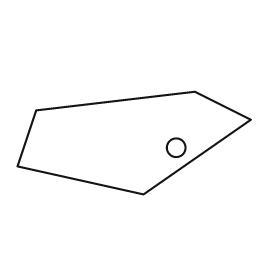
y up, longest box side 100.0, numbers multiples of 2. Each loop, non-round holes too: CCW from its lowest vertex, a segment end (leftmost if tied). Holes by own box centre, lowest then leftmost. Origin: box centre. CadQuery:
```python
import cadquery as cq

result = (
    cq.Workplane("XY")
    .moveTo(4.0, -22.0)
    .lineTo(50.0, 10.0)
    .lineTo(26.0, 22.0)
    .lineTo(-42.0, 14.0)
    .lineTo(-50.0, -10.0)
    .close()
    .moveTo(18.0, -2.0)
    .circle(4.0)
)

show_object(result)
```